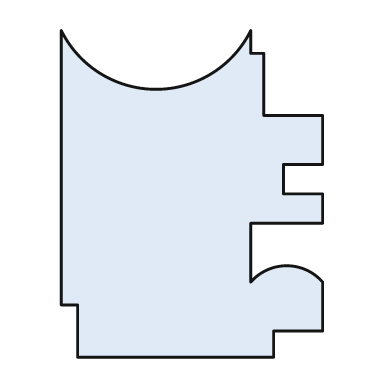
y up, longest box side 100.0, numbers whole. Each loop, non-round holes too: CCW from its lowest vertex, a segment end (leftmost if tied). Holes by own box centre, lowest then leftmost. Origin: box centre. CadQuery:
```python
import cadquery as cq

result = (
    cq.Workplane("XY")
    .moveTo(-35.0, -50.0)
    .lineTo(25.0, -50.0)
    .lineTo(25.0, -42.0)
    .lineTo(40.0, -42.0)
    .lineTo(40.0, -27.0)
    .threePointArc((29.0, -22.0), (18.0, -27.0))
    .lineTo(18.0, -9.0)
    .lineTo(40.0, -9.0)
    .lineTo(40.0, 0.0)
    .lineTo(28.0, 0.0)
    .lineTo(28.0, 9.0)
    .lineTo(40.0, 9.0)
    .lineTo(40.0, 24.0)
    .lineTo(22.0, 24.0)
    .lineTo(22.0, 43.0)
    .lineTo(18.0, 43.0)
    .lineTo(18.0, 50.0)
    .threePointArc((-11.0, 32.0), (-40.0, 50.0))
    .lineTo(-40.0, -34.0)
    .lineTo(-35.0, -34.0)
    .close()
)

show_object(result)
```